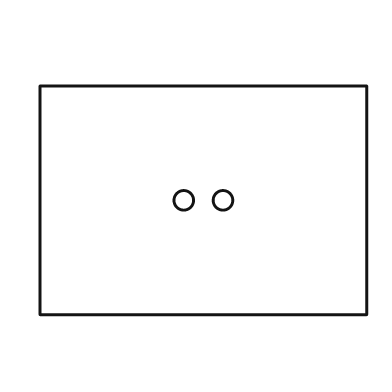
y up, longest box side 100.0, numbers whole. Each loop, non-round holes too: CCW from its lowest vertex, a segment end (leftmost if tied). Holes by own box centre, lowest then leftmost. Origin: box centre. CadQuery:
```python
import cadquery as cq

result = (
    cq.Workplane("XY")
    .moveTo(-50.0, -35.0)
    .lineTo(50.0, -35.0)
    .lineTo(50.0, 35.0)
    .lineTo(-50.0, 35.0)
    .close()
    .moveTo(-6.0, 0.0)
    .circle(3.0)
    .moveTo(6.0, 0.0)
    .circle(3.0)
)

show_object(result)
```